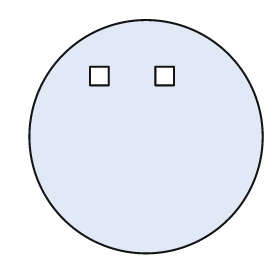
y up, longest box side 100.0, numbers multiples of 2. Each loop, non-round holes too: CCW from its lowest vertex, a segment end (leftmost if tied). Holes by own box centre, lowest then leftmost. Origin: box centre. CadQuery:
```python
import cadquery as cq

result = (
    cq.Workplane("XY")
    .moveTo(0.0, 0.0)
    .circle(50.0)
    .moveTo(-24.0, 22.0)
    .lineTo(-16.0, 22.0)
    .lineTo(-16.0, 30.0)
    .lineTo(-24.0, 30.0)
    .close()
    .moveTo(4.0, 22.0)
    .lineTo(12.0, 22.0)
    .lineTo(12.0, 30.0)
    .lineTo(4.0, 30.0)
    .close()
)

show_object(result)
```